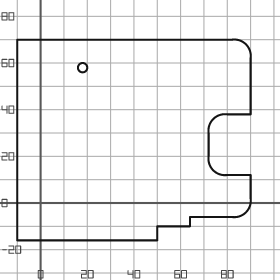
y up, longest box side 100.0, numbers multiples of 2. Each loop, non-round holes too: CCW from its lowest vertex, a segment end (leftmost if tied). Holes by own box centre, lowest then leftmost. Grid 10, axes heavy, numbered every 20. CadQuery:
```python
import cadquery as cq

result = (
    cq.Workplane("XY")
    .moveTo(-10.0, -16.0)
    .lineTo(50.0, -16.0)
    .lineTo(50.0, -10.0)
    .lineTo(64.0, -10.0)
    .lineTo(64.0, -6.0)
    .lineTo(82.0, -6.0)
    .threePointArc((88.0, -4.0), (90.0, 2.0))
    .lineTo(90.0, 12.0)
    .lineTo(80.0, 12.0)
    .threePointArc((74.0, 14.0), (72.0, 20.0))
    .lineTo(72.0, 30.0)
    .threePointArc((74.0, 36.0), (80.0, 38.0))
    .lineTo(90.0, 38.0)
    .lineTo(90.0, 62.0)
    .threePointArc((88.0, 68.0), (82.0, 70.0))
    .lineTo(-10.0, 70.0)
    .close()
    .moveTo(18.0, 58.0)
    .circle(2.0)
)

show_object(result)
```